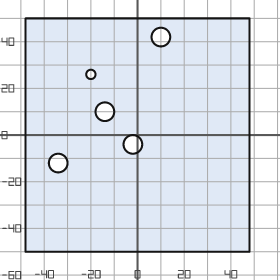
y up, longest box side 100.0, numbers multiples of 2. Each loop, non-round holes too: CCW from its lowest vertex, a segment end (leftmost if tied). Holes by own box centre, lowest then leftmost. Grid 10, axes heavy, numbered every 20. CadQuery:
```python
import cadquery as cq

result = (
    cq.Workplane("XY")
    .moveTo(-48.0, -50.0)
    .lineTo(48.0, -50.0)
    .lineTo(48.0, 50.0)
    .lineTo(-48.0, 50.0)
    .close()
    .moveTo(-34.0, -12.0)
    .circle(4.0)
    .moveTo(-2.0, -4.0)
    .circle(4.0)
    .moveTo(-14.0, 10.0)
    .circle(4.0)
    .moveTo(-20.0, 26.0)
    .circle(2.0)
    .moveTo(10.0, 42.0)
    .circle(4.0)
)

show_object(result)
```